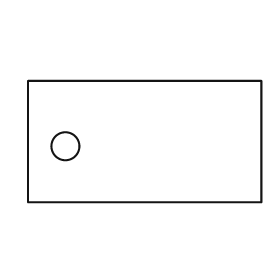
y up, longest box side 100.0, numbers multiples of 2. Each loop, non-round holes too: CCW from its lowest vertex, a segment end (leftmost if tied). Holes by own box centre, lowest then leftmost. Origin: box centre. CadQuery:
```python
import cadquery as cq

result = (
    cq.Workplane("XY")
    .moveTo(-50.0, -26.0)
    .lineTo(50.0, -26.0)
    .lineTo(50.0, 26.0)
    .lineTo(-50.0, 26.0)
    .close()
    .moveTo(-34.0, -2.0)
    .circle(6.0)
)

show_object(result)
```